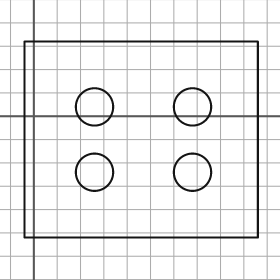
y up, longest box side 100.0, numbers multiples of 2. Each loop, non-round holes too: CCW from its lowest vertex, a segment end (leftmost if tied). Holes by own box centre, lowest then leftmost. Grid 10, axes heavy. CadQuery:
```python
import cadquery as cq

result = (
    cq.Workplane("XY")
    .moveTo(-4.0, -52.0)
    .lineTo(96.0, -52.0)
    .lineTo(96.0, 32.0)
    .lineTo(-4.0, 32.0)
    .close()
    .moveTo(26.0, -24.0)
    .circle(8.0)
    .moveTo(68.0, -24.0)
    .circle(8.0)
    .moveTo(26.0, 4.0)
    .circle(8.0)
    .moveTo(68.0, 4.0)
    .circle(8.0)
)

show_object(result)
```